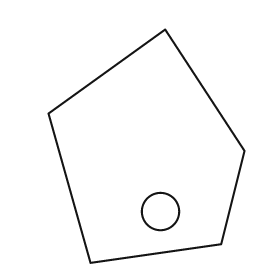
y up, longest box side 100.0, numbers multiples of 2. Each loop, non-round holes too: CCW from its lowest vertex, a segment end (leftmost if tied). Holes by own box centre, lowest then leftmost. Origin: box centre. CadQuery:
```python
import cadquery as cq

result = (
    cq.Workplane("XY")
    .moveTo(-24.0, -50.0)
    .lineTo(32.0, -42.0)
    .lineTo(42.0, -2.0)
    .lineTo(8.0, 50.0)
    .lineTo(-42.0, 14.0)
    .close()
    .moveTo(6.0, -28.0)
    .circle(8.0)
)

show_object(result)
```